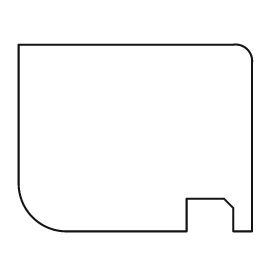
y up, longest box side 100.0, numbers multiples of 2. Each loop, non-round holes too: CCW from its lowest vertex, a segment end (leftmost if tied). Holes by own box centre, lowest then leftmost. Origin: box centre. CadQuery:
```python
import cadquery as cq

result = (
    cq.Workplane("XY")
    .moveTo(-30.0, -40.0)
    .lineTo(22.0, -40.0)
    .lineTo(22.0, -26.0)
    .lineTo(38.0, -26.0)
    .lineTo(42.0, -30.0)
    .lineTo(42.0, -40.0)
    .lineTo(50.0, -40.0)
    .lineTo(50.0, 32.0)
    .threePointArc((48.0, 38.0), (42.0, 40.0))
    .lineTo(-50.0, 40.0)
    .lineTo(-50.0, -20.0)
    .threePointArc((-44.0, -34.0), (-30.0, -40.0))
    .close()
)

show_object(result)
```